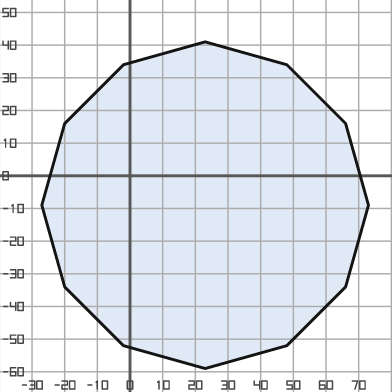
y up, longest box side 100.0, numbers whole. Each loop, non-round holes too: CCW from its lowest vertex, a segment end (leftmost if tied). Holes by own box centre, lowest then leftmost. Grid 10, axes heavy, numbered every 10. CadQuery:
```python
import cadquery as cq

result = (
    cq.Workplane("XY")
    .moveTo(23.0, -59.0)
    .lineTo(48.0, -52.0)
    .lineTo(66.0, -34.0)
    .lineTo(73.0, -9.0)
    .lineTo(66.0, 16.0)
    .lineTo(48.0, 34.0)
    .lineTo(23.0, 41.0)
    .lineTo(-2.0, 34.0)
    .lineTo(-20.0, 16.0)
    .lineTo(-27.0, -9.0)
    .lineTo(-20.0, -34.0)
    .lineTo(-2.0, -52.0)
    .close()
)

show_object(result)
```